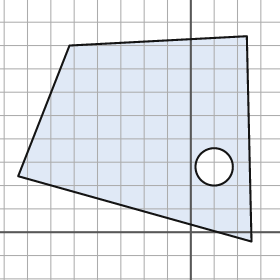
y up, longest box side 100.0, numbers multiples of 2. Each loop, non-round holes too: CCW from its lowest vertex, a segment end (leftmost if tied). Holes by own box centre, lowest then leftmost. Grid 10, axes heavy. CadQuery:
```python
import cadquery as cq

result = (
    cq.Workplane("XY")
    .moveTo(26.0, -4.0)
    .lineTo(24.0, 84.0)
    .lineTo(-52.0, 80.0)
    .lineTo(-74.0, 24.0)
    .close()
    .moveTo(10.0, 28.0)
    .circle(8.0)
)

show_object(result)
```